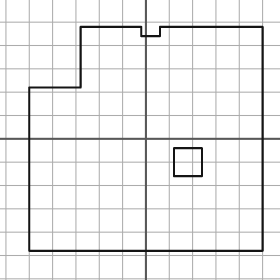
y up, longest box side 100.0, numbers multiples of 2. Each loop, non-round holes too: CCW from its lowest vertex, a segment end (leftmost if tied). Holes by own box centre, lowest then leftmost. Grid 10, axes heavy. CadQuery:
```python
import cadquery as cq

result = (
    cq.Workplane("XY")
    .moveTo(-50.0, -48.0)
    .lineTo(50.0, -48.0)
    .lineTo(50.0, 48.0)
    .lineTo(6.0, 48.0)
    .lineTo(6.0, 44.0)
    .lineTo(-2.0, 44.0)
    .lineTo(-2.0, 48.0)
    .lineTo(-28.0, 48.0)
    .lineTo(-28.0, 22.0)
    .lineTo(-50.0, 22.0)
    .close()
    .moveTo(12.0, -16.0)
    .lineTo(24.0, -16.0)
    .lineTo(24.0, -4.0)
    .lineTo(12.0, -4.0)
    .close()
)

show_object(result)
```